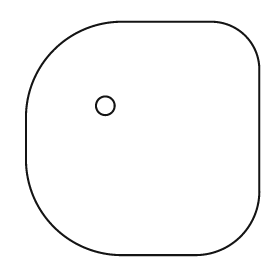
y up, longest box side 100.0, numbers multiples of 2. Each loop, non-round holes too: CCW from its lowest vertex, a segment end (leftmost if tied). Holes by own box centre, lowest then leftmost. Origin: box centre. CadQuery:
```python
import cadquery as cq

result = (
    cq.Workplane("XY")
    .moveTo(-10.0, -50.0)
    .lineTo(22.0, -50.0)
    .threePointArc((42.0, -42.0), (50.0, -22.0))
    .lineTo(50.0, 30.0)
    .threePointArc((44.0, 44.0), (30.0, 50.0))
    .lineTo(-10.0, 50.0)
    .threePointArc((-38.0, 38.0), (-50.0, 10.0))
    .lineTo(-50.0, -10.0)
    .threePointArc((-38.0, -38.0), (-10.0, -50.0))
    .close()
    .moveTo(-16.0, 14.0)
    .circle(4.0)
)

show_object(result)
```